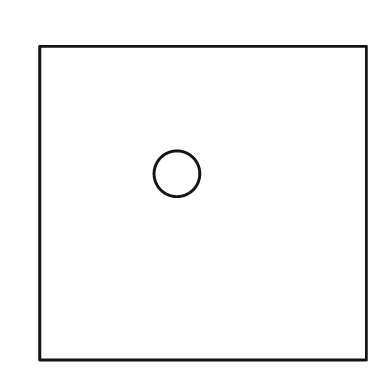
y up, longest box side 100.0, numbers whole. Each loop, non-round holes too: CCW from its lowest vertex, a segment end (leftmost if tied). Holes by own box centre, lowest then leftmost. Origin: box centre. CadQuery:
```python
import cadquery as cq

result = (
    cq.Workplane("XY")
    .moveTo(-50.0, -48.0)
    .lineTo(50.0, -48.0)
    .lineTo(50.0, 48.0)
    .lineTo(-50.0, 48.0)
    .close()
    .moveTo(-8.0, 9.0)
    .circle(7.0)
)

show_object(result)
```